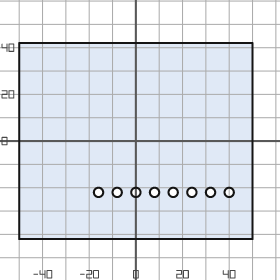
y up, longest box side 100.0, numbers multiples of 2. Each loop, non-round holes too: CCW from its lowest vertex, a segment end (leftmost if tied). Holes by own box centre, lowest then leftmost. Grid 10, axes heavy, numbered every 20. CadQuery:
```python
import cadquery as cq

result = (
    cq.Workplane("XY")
    .moveTo(-50.0, -42.0)
    .lineTo(50.0, -42.0)
    .lineTo(50.0, 42.0)
    .lineTo(-50.0, 42.0)
    .close()
    .moveTo(-16.0, -22.0)
    .circle(2.0)
    .moveTo(-8.0, -22.0)
    .circle(2.0)
    .moveTo(0.0, -22.0)
    .circle(2.0)
    .moveTo(8.0, -22.0)
    .circle(2.0)
    .moveTo(16.0, -22.0)
    .circle(2.0)
    .moveTo(24.0, -22.0)
    .circle(2.0)
    .moveTo(32.0, -22.0)
    .circle(2.0)
    .moveTo(40.0, -22.0)
    .circle(2.0)
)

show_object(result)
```